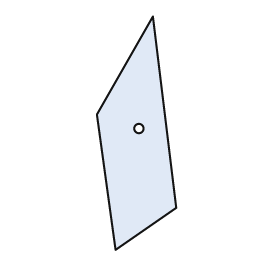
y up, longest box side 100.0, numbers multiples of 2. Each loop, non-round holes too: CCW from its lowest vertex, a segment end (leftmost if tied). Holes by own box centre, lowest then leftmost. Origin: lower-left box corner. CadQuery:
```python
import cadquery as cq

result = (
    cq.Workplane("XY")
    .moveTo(8.0, 0.0)
    .lineTo(34.0, 18.0)
    .lineTo(24.0, 100.0)
    .lineTo(0.0, 58.0)
    .close()
    .moveTo(18.0, 52.0)
    .circle(2.0)
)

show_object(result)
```